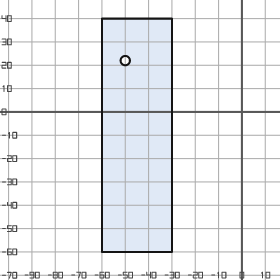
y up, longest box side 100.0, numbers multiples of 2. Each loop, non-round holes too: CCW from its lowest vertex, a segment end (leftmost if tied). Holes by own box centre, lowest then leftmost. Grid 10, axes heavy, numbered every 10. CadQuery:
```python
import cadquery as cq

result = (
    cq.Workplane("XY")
    .moveTo(-60.0, -60.0)
    .lineTo(-30.0, -60.0)
    .lineTo(-30.0, 40.0)
    .lineTo(-60.0, 40.0)
    .close()
    .moveTo(-50.0, 22.0)
    .circle(2.0)
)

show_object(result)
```